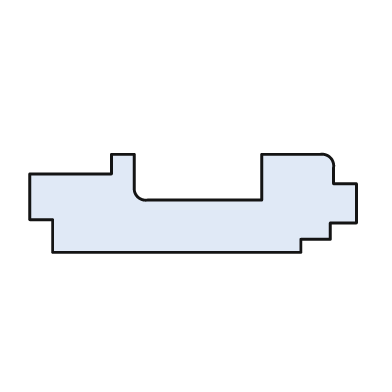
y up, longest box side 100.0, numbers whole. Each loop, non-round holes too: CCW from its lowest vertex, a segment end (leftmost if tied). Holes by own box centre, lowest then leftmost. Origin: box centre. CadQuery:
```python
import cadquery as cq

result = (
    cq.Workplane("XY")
    .moveTo(-43.0, -15.0)
    .lineTo(33.0, -15.0)
    .lineTo(33.0, -11.0)
    .lineTo(42.0, -11.0)
    .lineTo(42.0, -6.0)
    .lineTo(50.0, -6.0)
    .lineTo(50.0, 6.0)
    .lineTo(43.0, 6.0)
    .lineTo(43.0, 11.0)
    .threePointArc((42.0, 14.0), (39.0, 15.0))
    .lineTo(21.0, 15.0)
    .lineTo(21.0, 1.0)
    .lineTo(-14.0, 1.0)
    .threePointArc((-17.0, 2.0), (-18.0, 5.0))
    .lineTo(-18.0, 15.0)
    .lineTo(-25.0, 15.0)
    .lineTo(-25.0, 9.0)
    .lineTo(-50.0, 9.0)
    .lineTo(-50.0, -5.0)
    .lineTo(-43.0, -5.0)
    .close()
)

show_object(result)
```